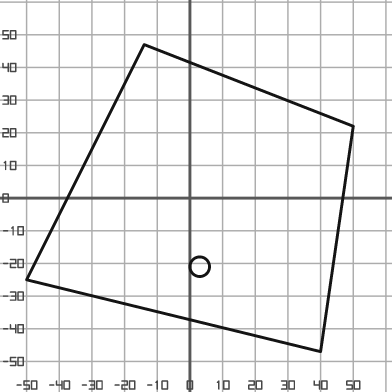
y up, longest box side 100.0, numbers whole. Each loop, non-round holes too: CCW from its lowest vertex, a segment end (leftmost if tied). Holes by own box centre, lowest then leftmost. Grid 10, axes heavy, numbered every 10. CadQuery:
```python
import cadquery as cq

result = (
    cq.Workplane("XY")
    .moveTo(40.0, -47.0)
    .lineTo(50.0, 22.0)
    .lineTo(-14.0, 47.0)
    .lineTo(-50.0, -25.0)
    .close()
    .moveTo(3.0, -21.0)
    .circle(3.0)
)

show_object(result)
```